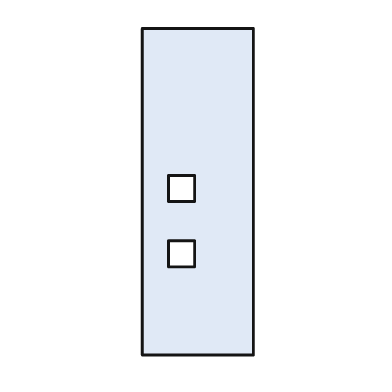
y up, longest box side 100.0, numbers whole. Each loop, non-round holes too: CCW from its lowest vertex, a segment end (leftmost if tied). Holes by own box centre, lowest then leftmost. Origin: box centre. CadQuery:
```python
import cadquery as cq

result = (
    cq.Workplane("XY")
    .moveTo(-17.0, -50.0)
    .lineTo(17.0, -50.0)
    .lineTo(17.0, 50.0)
    .lineTo(-17.0, 50.0)
    .close()
    .moveTo(-9.0, -23.0)
    .lineTo(-1.0, -23.0)
    .lineTo(-1.0, -15.0)
    .lineTo(-9.0, -15.0)
    .close()
    .moveTo(-9.0, -3.0)
    .lineTo(-1.0, -3.0)
    .lineTo(-1.0, 5.0)
    .lineTo(-9.0, 5.0)
    .close()
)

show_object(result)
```